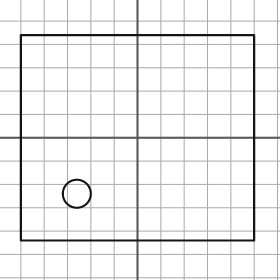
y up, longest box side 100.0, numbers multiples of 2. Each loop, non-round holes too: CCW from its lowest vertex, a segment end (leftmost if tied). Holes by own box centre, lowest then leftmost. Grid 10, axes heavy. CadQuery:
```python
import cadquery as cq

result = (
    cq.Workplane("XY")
    .moveTo(-50.0, -44.0)
    .lineTo(50.0, -44.0)
    .lineTo(50.0, 44.0)
    .lineTo(-50.0, 44.0)
    .close()
    .moveTo(-26.0, -24.0)
    .circle(6.0)
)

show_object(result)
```